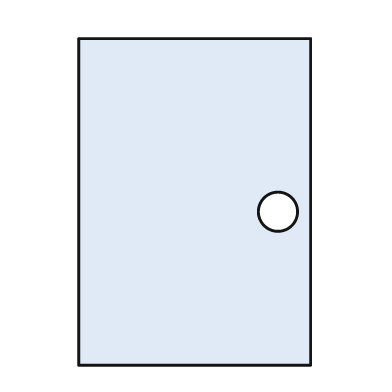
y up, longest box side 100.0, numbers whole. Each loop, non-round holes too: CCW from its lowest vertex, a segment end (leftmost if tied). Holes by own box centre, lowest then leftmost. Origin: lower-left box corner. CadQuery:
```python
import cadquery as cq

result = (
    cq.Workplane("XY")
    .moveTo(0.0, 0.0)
    .lineTo(71.0, 0.0)
    .lineTo(71.0, 100.0)
    .lineTo(0.0, 100.0)
    .close()
    .moveTo(61.0, 47.0)
    .circle(6.0)
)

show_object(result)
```